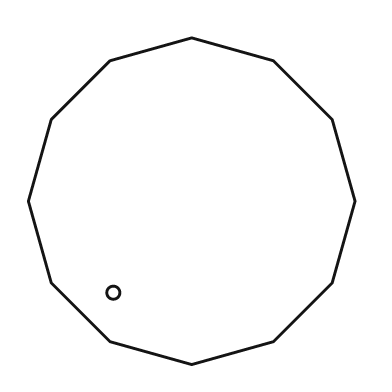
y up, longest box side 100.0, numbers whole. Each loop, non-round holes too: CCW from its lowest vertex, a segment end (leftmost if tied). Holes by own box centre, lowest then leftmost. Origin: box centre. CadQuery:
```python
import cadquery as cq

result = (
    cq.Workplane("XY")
    .moveTo(0.0, -50.0)
    .lineTo(25.0, -43.0)
    .lineTo(43.0, -25.0)
    .lineTo(50.0, 0.0)
    .lineTo(43.0, 25.0)
    .lineTo(25.0, 43.0)
    .lineTo(0.0, 50.0)
    .lineTo(-25.0, 43.0)
    .lineTo(-43.0, 25.0)
    .lineTo(-50.0, 0.0)
    .lineTo(-43.0, -25.0)
    .lineTo(-25.0, -43.0)
    .close()
    .moveTo(-24.0, -28.0)
    .circle(2.0)
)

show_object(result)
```